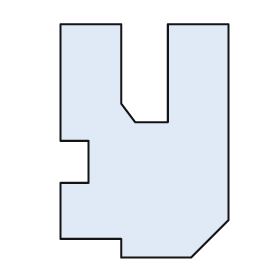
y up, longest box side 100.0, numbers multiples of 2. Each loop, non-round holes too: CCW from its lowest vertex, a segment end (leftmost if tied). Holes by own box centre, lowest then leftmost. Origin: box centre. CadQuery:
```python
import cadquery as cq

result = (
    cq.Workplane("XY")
    .moveTo(-10.0, -50.0)
    .lineTo(20.0, -50.0)
    .lineTo(36.0, -34.0)
    .lineTo(36.0, 50.0)
    .lineTo(10.0, 50.0)
    .lineTo(10.0, 8.0)
    .lineTo(-4.0, 8.0)
    .lineTo(-10.0, 16.0)
    .lineTo(-10.0, 50.0)
    .lineTo(-36.0, 50.0)
    .lineTo(-36.0, 0.0)
    .lineTo(-24.0, 0.0)
    .lineTo(-24.0, -18.0)
    .lineTo(-36.0, -18.0)
    .lineTo(-36.0, -42.0)
    .lineTo(-10.0, -42.0)
    .close()
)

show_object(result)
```